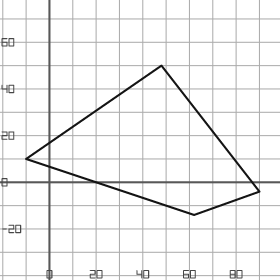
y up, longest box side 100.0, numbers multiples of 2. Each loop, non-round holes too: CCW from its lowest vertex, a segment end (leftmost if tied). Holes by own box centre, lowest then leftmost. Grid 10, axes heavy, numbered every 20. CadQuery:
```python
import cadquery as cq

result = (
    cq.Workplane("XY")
    .moveTo(62.0, -14.0)
    .lineTo(90.0, -4.0)
    .lineTo(48.0, 50.0)
    .lineTo(-10.0, 10.0)
    .close()
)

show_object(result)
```